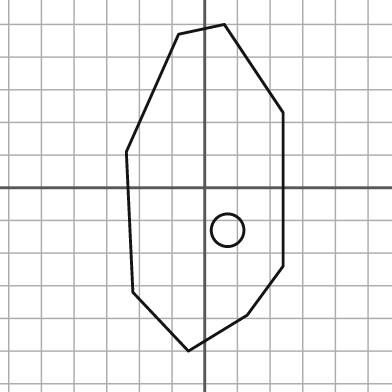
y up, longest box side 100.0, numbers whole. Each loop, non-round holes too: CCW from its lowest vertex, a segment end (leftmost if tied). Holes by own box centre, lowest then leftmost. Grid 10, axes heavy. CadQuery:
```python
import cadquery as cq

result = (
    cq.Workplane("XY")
    .moveTo(-5.0, -50.0)
    .lineTo(13.0, -39.0)
    .lineTo(24.0, -24.0)
    .lineTo(24.0, 23.0)
    .lineTo(6.0, 50.0)
    .lineTo(-8.0, 47.0)
    .lineTo(-24.0, 11.0)
    .lineTo(-22.0, -32.0)
    .close()
    .moveTo(7.0, -13.0)
    .circle(5.0)
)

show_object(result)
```